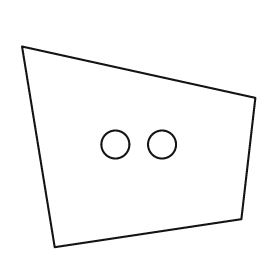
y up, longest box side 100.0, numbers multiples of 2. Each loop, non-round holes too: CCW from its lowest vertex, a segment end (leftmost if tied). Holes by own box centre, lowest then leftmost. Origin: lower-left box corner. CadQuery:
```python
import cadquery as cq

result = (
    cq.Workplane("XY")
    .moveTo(14.0, 0.0)
    .lineTo(94.0, 12.0)
    .lineTo(100.0, 64.0)
    .lineTo(0.0, 86.0)
    .close()
    .moveTo(40.0, 44.0)
    .circle(6.0)
    .moveTo(60.0, 44.0)
    .circle(6.0)
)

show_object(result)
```